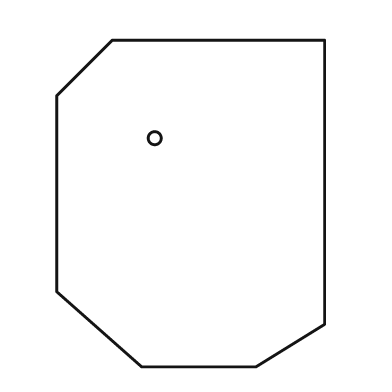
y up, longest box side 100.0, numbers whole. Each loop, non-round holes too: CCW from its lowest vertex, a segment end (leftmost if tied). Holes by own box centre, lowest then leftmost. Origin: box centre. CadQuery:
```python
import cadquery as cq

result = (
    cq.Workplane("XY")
    .moveTo(-15.0, -50.0)
    .lineTo(20.0, -50.0)
    .lineTo(41.0, -37.0)
    .lineTo(41.0, 50.0)
    .lineTo(-24.0, 50.0)
    .lineTo(-41.0, 33.0)
    .lineTo(-41.0, -27.0)
    .close()
    .moveTo(-11.0, 20.0)
    .circle(2.0)
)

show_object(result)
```